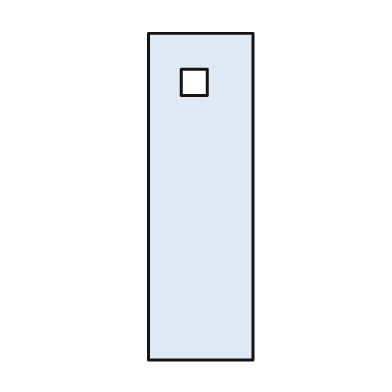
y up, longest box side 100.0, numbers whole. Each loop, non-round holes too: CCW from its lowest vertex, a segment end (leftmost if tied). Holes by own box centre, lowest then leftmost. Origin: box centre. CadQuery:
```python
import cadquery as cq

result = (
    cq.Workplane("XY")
    .moveTo(-16.0, -50.0)
    .lineTo(16.0, -50.0)
    .lineTo(16.0, 50.0)
    .lineTo(-16.0, 50.0)
    .close()
    .moveTo(-6.0, 31.0)
    .lineTo(2.0, 31.0)
    .lineTo(2.0, 39.0)
    .lineTo(-6.0, 39.0)
    .close()
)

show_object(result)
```